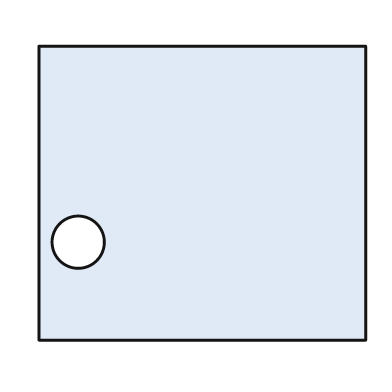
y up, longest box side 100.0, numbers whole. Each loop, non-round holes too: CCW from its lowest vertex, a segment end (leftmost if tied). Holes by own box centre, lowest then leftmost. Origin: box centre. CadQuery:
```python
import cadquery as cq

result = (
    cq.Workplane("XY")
    .moveTo(-50.0, -45.0)
    .lineTo(50.0, -45.0)
    .lineTo(50.0, 45.0)
    .lineTo(-50.0, 45.0)
    .close()
    .moveTo(-38.0, -15.0)
    .circle(8.0)
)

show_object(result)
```